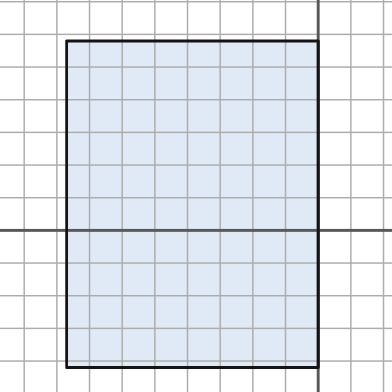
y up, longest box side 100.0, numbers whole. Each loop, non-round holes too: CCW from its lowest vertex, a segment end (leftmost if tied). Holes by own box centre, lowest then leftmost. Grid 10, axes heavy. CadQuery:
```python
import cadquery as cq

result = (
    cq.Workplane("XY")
    .moveTo(-77.0, -42.0)
    .lineTo(0.0, -42.0)
    .lineTo(0.0, 58.0)
    .lineTo(-77.0, 58.0)
    .close()
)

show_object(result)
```